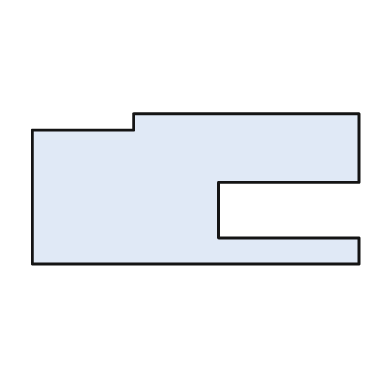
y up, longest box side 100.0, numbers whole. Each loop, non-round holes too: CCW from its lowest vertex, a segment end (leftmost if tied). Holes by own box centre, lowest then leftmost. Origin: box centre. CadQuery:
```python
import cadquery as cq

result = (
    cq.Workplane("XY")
    .moveTo(-50.0, -23.0)
    .lineTo(50.0, -23.0)
    .lineTo(50.0, -15.0)
    .lineTo(7.0, -15.0)
    .lineTo(7.0, 2.0)
    .lineTo(50.0, 2.0)
    .lineTo(50.0, 23.0)
    .lineTo(-19.0, 23.0)
    .lineTo(-19.0, 18.0)
    .lineTo(-50.0, 18.0)
    .close()
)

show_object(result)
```